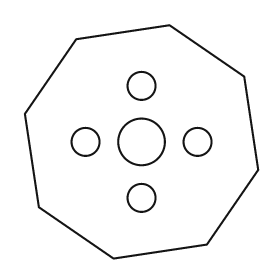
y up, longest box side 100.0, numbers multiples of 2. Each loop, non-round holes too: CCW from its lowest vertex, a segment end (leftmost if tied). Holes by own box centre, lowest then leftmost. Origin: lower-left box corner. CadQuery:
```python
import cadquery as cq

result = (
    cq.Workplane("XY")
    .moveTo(38.0, 0.0)
    .lineTo(78.0, 6.0)
    .lineTo(100.0, 38.0)
    .lineTo(94.0, 78.0)
    .lineTo(62.0, 100.0)
    .lineTo(22.0, 94.0)
    .lineTo(0.0, 62.0)
    .lineTo(6.0, 22.0)
    .close()
    .moveTo(50.0, 26.0)
    .circle(6.0)
    .moveTo(26.0, 50.0)
    .circle(6.0)
    .moveTo(50.0, 50.0)
    .circle(10.0)
    .moveTo(74.0, 50.0)
    .circle(6.0)
    .moveTo(50.0, 74.0)
    .circle(6.0)
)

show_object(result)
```